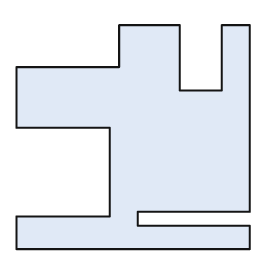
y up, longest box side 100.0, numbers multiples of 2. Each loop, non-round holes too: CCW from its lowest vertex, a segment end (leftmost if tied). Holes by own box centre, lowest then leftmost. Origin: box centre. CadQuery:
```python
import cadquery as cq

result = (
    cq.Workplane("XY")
    .moveTo(-50.0, -48.0)
    .lineTo(50.0, -48.0)
    .lineTo(50.0, -38.0)
    .lineTo(2.0, -38.0)
    .lineTo(2.0, -32.0)
    .lineTo(50.0, -32.0)
    .lineTo(50.0, 48.0)
    .lineTo(38.0, 48.0)
    .lineTo(38.0, 20.0)
    .lineTo(20.0, 20.0)
    .lineTo(20.0, 48.0)
    .lineTo(-6.0, 48.0)
    .lineTo(-6.0, 30.0)
    .lineTo(-50.0, 30.0)
    .lineTo(-50.0, 4.0)
    .lineTo(-10.0, 4.0)
    .lineTo(-10.0, -34.0)
    .lineTo(-50.0, -34.0)
    .close()
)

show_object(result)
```